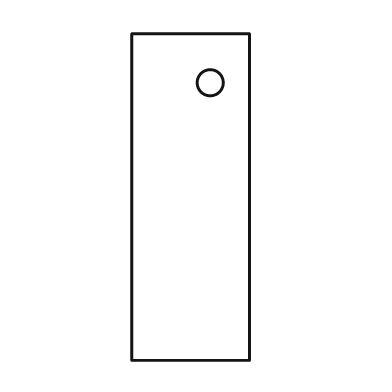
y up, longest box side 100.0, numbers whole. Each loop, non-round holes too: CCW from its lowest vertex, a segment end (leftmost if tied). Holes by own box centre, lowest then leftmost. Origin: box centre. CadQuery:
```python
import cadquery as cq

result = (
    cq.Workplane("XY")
    .moveTo(-18.0, -50.0)
    .lineTo(18.0, -50.0)
    .lineTo(18.0, 50.0)
    .lineTo(-18.0, 50.0)
    .close()
    .moveTo(6.0, 35.0)
    .circle(4.0)
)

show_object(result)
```